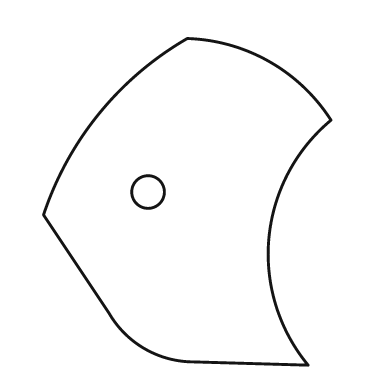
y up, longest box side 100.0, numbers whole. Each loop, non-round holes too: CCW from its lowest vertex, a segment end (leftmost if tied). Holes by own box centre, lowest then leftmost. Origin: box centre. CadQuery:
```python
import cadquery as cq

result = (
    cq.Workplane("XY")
    .moveTo(37.0, -50.0)
    .threePointArc((25.0, -11.0), (44.0, 25.0))
    .threePointArc((25.0, 43.0), (0.0, 50.0))
    .threePointArc((-27.0, 27.0), (-44.0, -4.0))
    .lineTo(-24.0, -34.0)
    .threePointArc((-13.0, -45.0), (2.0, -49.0))
    .close()
    .moveTo(-12.0, 3.0)
    .circle(5.0)
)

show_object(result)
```